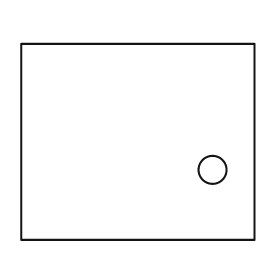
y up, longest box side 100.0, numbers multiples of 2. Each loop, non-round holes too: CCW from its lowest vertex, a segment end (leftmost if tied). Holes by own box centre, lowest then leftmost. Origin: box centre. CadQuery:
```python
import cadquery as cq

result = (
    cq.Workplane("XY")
    .moveTo(-50.0, -42.0)
    .lineTo(50.0, -42.0)
    .lineTo(50.0, 42.0)
    .lineTo(-50.0, 42.0)
    .close()
    .moveTo(32.0, -12.0)
    .circle(6.0)
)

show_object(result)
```